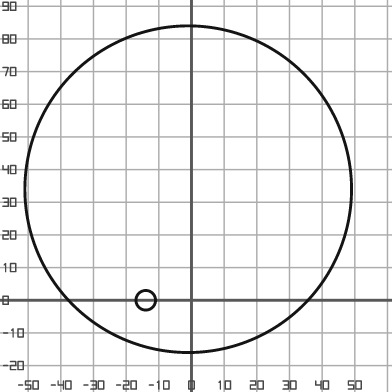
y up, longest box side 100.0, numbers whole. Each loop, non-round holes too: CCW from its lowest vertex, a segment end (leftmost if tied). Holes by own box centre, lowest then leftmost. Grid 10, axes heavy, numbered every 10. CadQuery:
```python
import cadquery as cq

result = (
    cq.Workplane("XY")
    .moveTo(-1.0, 34.0)
    .circle(50.0)
    .moveTo(-14.0, 0.0)
    .circle(3.0)
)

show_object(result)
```